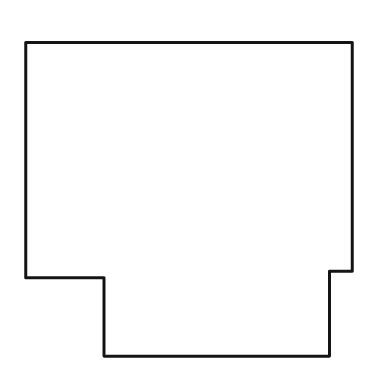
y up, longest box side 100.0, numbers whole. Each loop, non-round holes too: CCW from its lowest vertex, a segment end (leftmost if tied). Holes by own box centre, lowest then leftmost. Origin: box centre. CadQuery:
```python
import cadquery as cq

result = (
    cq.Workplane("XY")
    .moveTo(-26.0, -48.0)
    .lineTo(43.0, -48.0)
    .lineTo(43.0, -22.0)
    .lineTo(50.0, -22.0)
    .lineTo(50.0, 48.0)
    .lineTo(-50.0, 48.0)
    .lineTo(-50.0, -24.0)
    .lineTo(-26.0, -24.0)
    .close()
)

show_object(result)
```